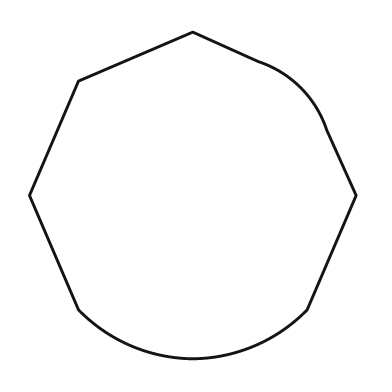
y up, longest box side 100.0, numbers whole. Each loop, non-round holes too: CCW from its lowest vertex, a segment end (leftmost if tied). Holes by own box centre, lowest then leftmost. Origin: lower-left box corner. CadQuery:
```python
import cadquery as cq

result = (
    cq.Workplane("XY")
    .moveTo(50.0, 0.0)
    .threePointArc((69.0, 4.0), (85.0, 15.0))
    .lineTo(100.0, 50.0)
    .lineTo(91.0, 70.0)
    .threePointArc((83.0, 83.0), (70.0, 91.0))
    .lineTo(50.0, 100.0)
    .lineTo(15.0, 85.0)
    .lineTo(0.0, 50.0)
    .lineTo(15.0, 15.0)
    .threePointArc((31.0, 4.0), (50.0, 0.0))
    .close()
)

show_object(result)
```